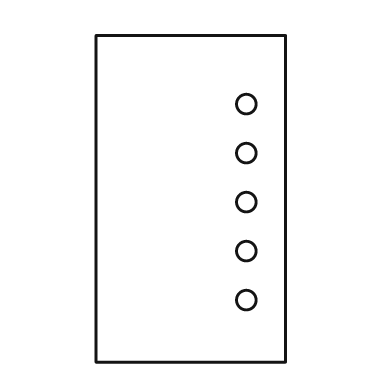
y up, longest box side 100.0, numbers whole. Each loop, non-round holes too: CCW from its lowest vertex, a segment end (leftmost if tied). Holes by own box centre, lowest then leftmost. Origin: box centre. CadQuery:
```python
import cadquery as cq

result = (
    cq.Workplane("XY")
    .moveTo(-29.0, -50.0)
    .lineTo(29.0, -50.0)
    .lineTo(29.0, 50.0)
    .lineTo(-29.0, 50.0)
    .close()
    .moveTo(17.0, -31.0)
    .circle(3.0)
    .moveTo(17.0, -16.0)
    .circle(3.0)
    .moveTo(17.0, -1.0)
    .circle(3.0)
    .moveTo(17.0, 14.0)
    .circle(3.0)
    .moveTo(17.0, 29.0)
    .circle(3.0)
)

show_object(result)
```